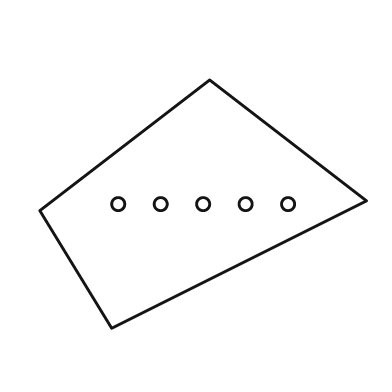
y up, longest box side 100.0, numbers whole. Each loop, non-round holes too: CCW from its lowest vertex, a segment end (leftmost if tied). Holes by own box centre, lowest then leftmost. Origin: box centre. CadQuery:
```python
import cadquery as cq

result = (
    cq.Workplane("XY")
    .moveTo(-28.0, -38.0)
    .lineTo(50.0, 1.0)
    .lineTo(2.0, 38.0)
    .lineTo(-50.0, -2.0)
    .close()
    .moveTo(-26.0, 0.0)
    .circle(2.0)
    .moveTo(-13.0, 0.0)
    .circle(2.0)
    .moveTo(0.0, 0.0)
    .circle(2.0)
    .moveTo(13.0, 0.0)
    .circle(2.0)
    .moveTo(26.0, 0.0)
    .circle(2.0)
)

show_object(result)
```